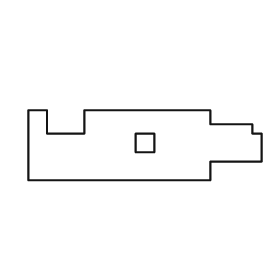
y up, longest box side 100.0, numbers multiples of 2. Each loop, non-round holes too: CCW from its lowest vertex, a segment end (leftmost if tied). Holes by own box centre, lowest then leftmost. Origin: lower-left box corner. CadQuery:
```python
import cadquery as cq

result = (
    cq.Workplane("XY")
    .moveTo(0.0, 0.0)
    .lineTo(78.0, 0.0)
    .lineTo(78.0, 8.0)
    .lineTo(100.0, 8.0)
    .lineTo(100.0, 20.0)
    .lineTo(96.0, 20.0)
    .lineTo(96.0, 24.0)
    .lineTo(78.0, 24.0)
    .lineTo(78.0, 30.0)
    .lineTo(24.0, 30.0)
    .lineTo(24.0, 20.0)
    .lineTo(8.0, 20.0)
    .lineTo(8.0, 30.0)
    .lineTo(0.0, 30.0)
    .close()
    .moveTo(46.0, 12.0)
    .lineTo(54.0, 12.0)
    .lineTo(54.0, 20.0)
    .lineTo(46.0, 20.0)
    .close()
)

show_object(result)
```